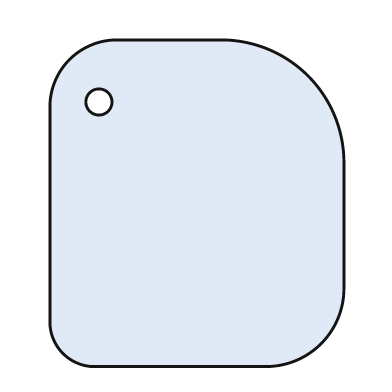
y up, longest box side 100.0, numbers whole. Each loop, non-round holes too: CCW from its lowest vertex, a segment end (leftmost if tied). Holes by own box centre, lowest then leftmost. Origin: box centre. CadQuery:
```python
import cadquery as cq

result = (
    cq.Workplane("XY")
    .moveTo(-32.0, -50.0)
    .lineTo(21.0, -50.0)
    .threePointArc((38.0, -43.0), (45.0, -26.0))
    .lineTo(45.0, 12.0)
    .threePointArc((34.0, 39.0), (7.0, 50.0))
    .lineTo(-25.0, 50.0)
    .threePointArc((-39.0, 44.0), (-45.0, 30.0))
    .lineTo(-45.0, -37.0)
    .threePointArc((-41.0, -46.0), (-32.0, -50.0))
    .close()
    .moveTo(-30.0, 31.0)
    .circle(4.0)
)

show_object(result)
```